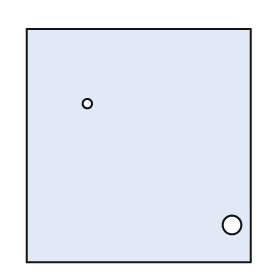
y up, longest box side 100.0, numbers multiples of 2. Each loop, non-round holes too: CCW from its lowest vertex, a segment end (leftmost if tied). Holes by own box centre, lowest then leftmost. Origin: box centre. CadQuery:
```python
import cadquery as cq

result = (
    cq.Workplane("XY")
    .moveTo(-48.0, -50.0)
    .lineTo(48.0, -50.0)
    .lineTo(48.0, 50.0)
    .lineTo(-48.0, 50.0)
    .close()
    .moveTo(40.0, -34.0)
    .circle(4.0)
    .moveTo(-22.0, 18.0)
    .circle(2.0)
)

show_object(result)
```